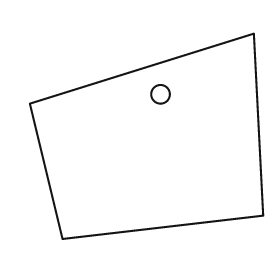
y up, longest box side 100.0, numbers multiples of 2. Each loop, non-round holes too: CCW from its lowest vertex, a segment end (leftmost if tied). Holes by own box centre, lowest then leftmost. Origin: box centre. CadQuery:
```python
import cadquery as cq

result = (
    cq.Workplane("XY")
    .moveTo(-36.0, -44.0)
    .lineTo(50.0, -34.0)
    .lineTo(46.0, 44.0)
    .lineTo(-50.0, 14.0)
    .close()
    .moveTo(6.0, 18.0)
    .circle(4.0)
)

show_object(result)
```